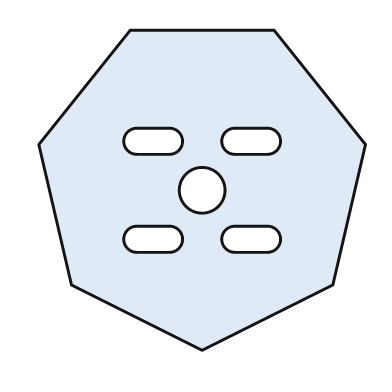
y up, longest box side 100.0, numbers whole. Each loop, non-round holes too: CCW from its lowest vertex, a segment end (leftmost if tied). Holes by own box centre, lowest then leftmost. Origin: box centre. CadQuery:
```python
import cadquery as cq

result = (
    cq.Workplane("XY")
    .moveTo(0.0, -49.0)
    .lineTo(40.0, -29.0)
    .lineTo(50.0, 14.0)
    .lineTo(22.0, 49.0)
    .lineTo(-22.0, 49.0)
    .lineTo(-50.0, 14.0)
    .lineTo(-40.0, -29.0)
    .close()
    .moveTo(-20.0, -19.0)
    .lineTo(-10.0, -19.0)
    .threePointArc((-6.0, -15.0), (-10.0, -11.0))
    .lineTo(-20.0, -11.0)
    .threePointArc((-24.0, -15.0), (-20.0, -19.0))
    .close()
    .moveTo(10.0, -19.0)
    .lineTo(20.0, -19.0)
    .threePointArc((24.0, -15.0), (20.0, -11.0))
    .lineTo(10.0, -11.0)
    .threePointArc((6.0, -15.0), (10.0, -19.0))
    .close()
    .moveTo(0.0, 0.0)
    .circle(7.0)
    .moveTo(-20.0, 11.0)
    .lineTo(-10.0, 11.0)
    .threePointArc((-6.0, 15.0), (-10.0, 19.0))
    .lineTo(-20.0, 19.0)
    .threePointArc((-24.0, 15.0), (-20.0, 11.0))
    .close()
    .moveTo(10.0, 11.0)
    .lineTo(20.0, 11.0)
    .threePointArc((24.0, 15.0), (20.0, 19.0))
    .lineTo(10.0, 19.0)
    .threePointArc((6.0, 15.0), (10.0, 11.0))
    .close()
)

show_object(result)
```